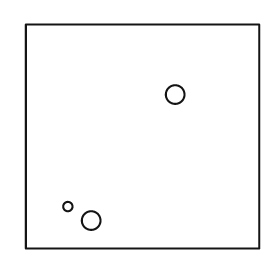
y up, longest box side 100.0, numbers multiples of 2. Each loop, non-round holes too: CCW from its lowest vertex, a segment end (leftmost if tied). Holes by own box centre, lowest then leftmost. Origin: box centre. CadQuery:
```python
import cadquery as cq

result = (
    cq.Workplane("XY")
    .moveTo(-50.0, -48.0)
    .lineTo(50.0, -48.0)
    .lineTo(50.0, 48.0)
    .lineTo(-50.0, 48.0)
    .close()
    .moveTo(-22.0, -36.0)
    .circle(4.0)
    .moveTo(-32.0, -30.0)
    .circle(2.0)
    .moveTo(14.0, 18.0)
    .circle(4.0)
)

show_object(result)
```